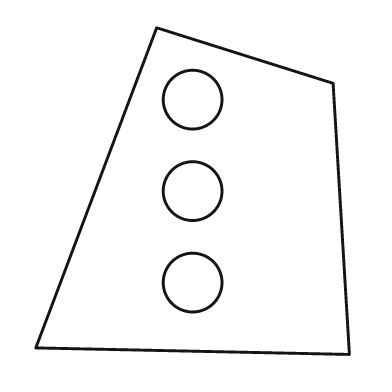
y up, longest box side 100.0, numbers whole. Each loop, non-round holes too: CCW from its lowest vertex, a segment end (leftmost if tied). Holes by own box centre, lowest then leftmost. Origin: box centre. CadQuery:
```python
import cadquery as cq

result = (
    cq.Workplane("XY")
    .moveTo(48.0, -50.0)
    .lineTo(43.0, 33.0)
    .lineTo(-11.0, 50.0)
    .lineTo(-48.0, -48.0)
    .close()
    .moveTo(0.0, -28.0)
    .circle(9.0)
    .moveTo(0.0, 0.0)
    .circle(9.0)
    .moveTo(0.0, 28.0)
    .circle(9.0)
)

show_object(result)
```